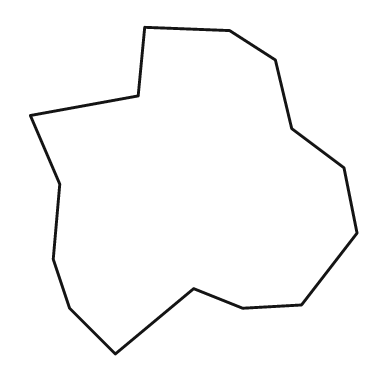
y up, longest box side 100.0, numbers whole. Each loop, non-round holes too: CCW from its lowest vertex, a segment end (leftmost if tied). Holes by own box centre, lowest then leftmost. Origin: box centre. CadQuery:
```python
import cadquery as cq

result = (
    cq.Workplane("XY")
    .moveTo(-24.0, -50.0)
    .lineTo(0.0, -30.0)
    .lineTo(15.0, -36.0)
    .lineTo(33.0, -35.0)
    .lineTo(50.0, -13.0)
    .lineTo(46.0, 7.0)
    .lineTo(30.0, 19.0)
    .lineTo(25.0, 40.0)
    .lineTo(11.0, 49.0)
    .lineTo(-15.0, 50.0)
    .lineTo(-17.0, 29.0)
    .lineTo(-50.0, 23.0)
    .lineTo(-41.0, 2.0)
    .lineTo(-43.0, -21.0)
    .lineTo(-38.0, -36.0)
    .close()
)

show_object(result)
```